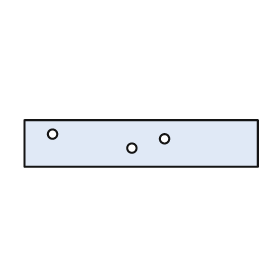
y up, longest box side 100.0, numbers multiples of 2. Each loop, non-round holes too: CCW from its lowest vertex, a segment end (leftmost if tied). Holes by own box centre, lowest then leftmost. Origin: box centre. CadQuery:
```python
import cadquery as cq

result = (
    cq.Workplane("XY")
    .moveTo(-50.0, -10.0)
    .lineTo(50.0, -10.0)
    .lineTo(50.0, 10.0)
    .lineTo(-50.0, 10.0)
    .close()
    .moveTo(-4.0, -2.0)
    .circle(2.0)
    .moveTo(10.0, 2.0)
    .circle(2.0)
    .moveTo(-38.0, 4.0)
    .circle(2.0)
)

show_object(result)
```